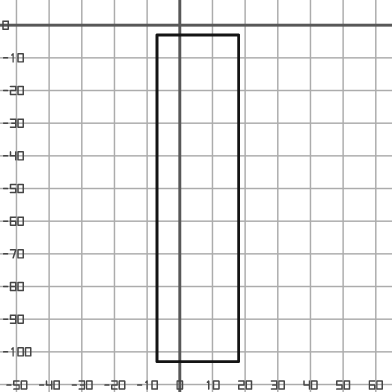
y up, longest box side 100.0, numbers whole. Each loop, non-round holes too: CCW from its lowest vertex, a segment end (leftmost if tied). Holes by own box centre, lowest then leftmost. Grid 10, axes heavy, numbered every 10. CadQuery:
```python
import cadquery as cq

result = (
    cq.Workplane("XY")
    .moveTo(-7.0, -103.0)
    .lineTo(18.0, -103.0)
    .lineTo(18.0, -3.0)
    .lineTo(-7.0, -3.0)
    .close()
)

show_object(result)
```